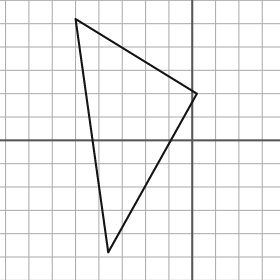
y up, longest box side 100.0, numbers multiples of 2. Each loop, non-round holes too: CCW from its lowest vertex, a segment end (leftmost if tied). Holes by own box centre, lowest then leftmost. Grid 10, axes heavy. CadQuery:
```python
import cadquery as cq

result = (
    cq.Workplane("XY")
    .moveTo(-36.0, -48.0)
    .lineTo(2.0, 20.0)
    .lineTo(-50.0, 52.0)
    .close()
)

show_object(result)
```